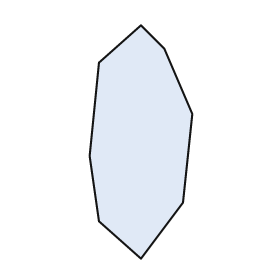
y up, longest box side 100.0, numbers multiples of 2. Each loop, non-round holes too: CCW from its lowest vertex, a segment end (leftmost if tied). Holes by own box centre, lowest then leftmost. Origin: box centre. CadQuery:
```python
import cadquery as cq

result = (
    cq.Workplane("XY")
    .moveTo(0.0, -50.0)
    .lineTo(18.0, -26.0)
    .lineTo(22.0, 12.0)
    .lineTo(10.0, 40.0)
    .lineTo(0.0, 50.0)
    .lineTo(-18.0, 34.0)
    .lineTo(-22.0, -6.0)
    .lineTo(-18.0, -34.0)
    .close()
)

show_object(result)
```